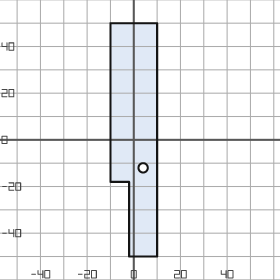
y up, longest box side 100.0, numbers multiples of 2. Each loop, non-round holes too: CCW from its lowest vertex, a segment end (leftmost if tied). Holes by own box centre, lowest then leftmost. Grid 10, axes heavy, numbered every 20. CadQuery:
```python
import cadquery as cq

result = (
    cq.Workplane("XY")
    .moveTo(-2.0, -50.0)
    .lineTo(10.0, -50.0)
    .lineTo(10.0, 50.0)
    .lineTo(-10.0, 50.0)
    .lineTo(-10.0, -18.0)
    .lineTo(-2.0, -18.0)
    .close()
    .moveTo(4.0, -12.0)
    .circle(2.0)
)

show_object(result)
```